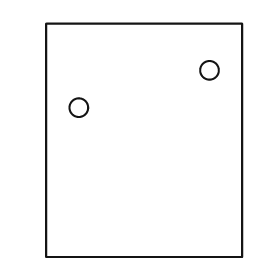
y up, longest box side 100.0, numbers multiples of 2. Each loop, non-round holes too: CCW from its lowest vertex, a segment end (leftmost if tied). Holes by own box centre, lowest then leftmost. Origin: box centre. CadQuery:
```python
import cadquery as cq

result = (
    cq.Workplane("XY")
    .moveTo(-42.0, -50.0)
    .lineTo(42.0, -50.0)
    .lineTo(42.0, 50.0)
    .lineTo(-42.0, 50.0)
    .close()
    .moveTo(-28.0, 14.0)
    .circle(4.0)
    .moveTo(28.0, 30.0)
    .circle(4.0)
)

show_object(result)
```